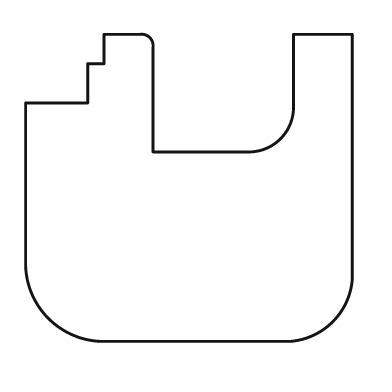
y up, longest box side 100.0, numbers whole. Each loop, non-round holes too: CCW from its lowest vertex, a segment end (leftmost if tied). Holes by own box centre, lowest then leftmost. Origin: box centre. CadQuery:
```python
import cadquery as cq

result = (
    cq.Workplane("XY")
    .moveTo(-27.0, -47.0)
    .lineTo(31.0, -47.0)
    .threePointArc((44.0, -41.0), (50.0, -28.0))
    .lineTo(50.0, 47.0)
    .lineTo(32.0, 47.0)
    .lineTo(32.0, 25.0)
    .threePointArc((28.0, 15.0), (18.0, 11.0))
    .lineTo(-11.0, 11.0)
    .lineTo(-11.0, 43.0)
    .threePointArc((-12.0, 46.0), (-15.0, 47.0))
    .lineTo(-26.0, 47.0)
    .lineTo(-26.0, 38.0)
    .lineTo(-31.0, 38.0)
    .lineTo(-31.0, 26.0)
    .lineTo(-50.0, 26.0)
    .lineTo(-50.0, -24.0)
    .threePointArc((-43.0, -40.0), (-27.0, -47.0))
    .close()
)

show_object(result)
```